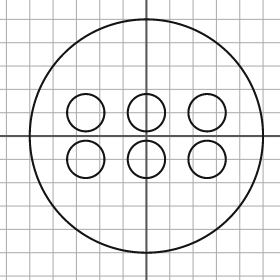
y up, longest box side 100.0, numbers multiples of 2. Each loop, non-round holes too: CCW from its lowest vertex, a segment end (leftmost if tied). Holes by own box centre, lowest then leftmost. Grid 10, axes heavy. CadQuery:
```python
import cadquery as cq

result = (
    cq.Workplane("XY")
    .moveTo(0.0, 0.0)
    .circle(50.0)
    .moveTo(-26.0, -10.0)
    .circle(8.0)
    .moveTo(0.0, -10.0)
    .circle(8.0)
    .moveTo(26.0, -10.0)
    .circle(8.0)
    .moveTo(-26.0, 10.0)
    .circle(8.0)
    .moveTo(0.0, 10.0)
    .circle(8.0)
    .moveTo(26.0, 10.0)
    .circle(8.0)
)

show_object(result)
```